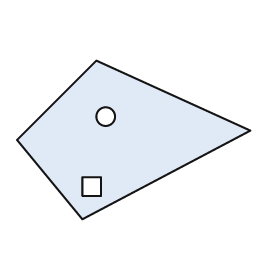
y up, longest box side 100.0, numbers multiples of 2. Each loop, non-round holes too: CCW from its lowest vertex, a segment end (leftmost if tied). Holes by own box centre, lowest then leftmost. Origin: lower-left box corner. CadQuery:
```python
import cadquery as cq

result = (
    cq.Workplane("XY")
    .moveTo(28.0, 0.0)
    .lineTo(100.0, 38.0)
    .lineTo(34.0, 68.0)
    .lineTo(0.0, 34.0)
    .close()
    .moveTo(28.0, 10.0)
    .lineTo(36.0, 10.0)
    .lineTo(36.0, 18.0)
    .lineTo(28.0, 18.0)
    .close()
    .moveTo(38.0, 44.0)
    .circle(4.0)
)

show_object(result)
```